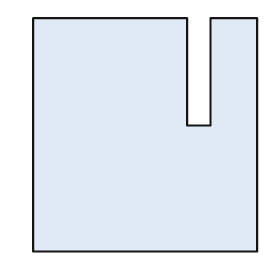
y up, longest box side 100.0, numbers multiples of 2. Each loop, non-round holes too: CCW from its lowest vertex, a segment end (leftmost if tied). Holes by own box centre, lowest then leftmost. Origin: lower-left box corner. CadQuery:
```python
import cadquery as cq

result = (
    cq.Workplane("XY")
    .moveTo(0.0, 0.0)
    .lineTo(96.0, 0.0)
    .lineTo(96.0, 100.0)
    .lineTo(76.0, 100.0)
    .lineTo(76.0, 54.0)
    .lineTo(66.0, 54.0)
    .lineTo(66.0, 100.0)
    .lineTo(0.0, 100.0)
    .close()
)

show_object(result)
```